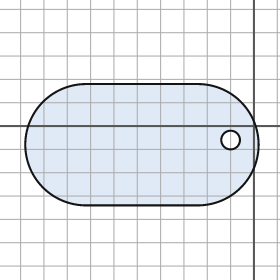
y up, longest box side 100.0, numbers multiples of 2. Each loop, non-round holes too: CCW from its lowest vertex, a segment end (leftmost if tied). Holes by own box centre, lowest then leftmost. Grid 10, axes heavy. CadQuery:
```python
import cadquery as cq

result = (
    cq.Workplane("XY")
    .moveTo(-72.0, -34.0)
    .lineTo(-24.0, -34.0)
    .threePointArc((2.0, -8.0), (-24.0, 18.0))
    .lineTo(-72.0, 18.0)
    .threePointArc((-98.0, -8.0), (-72.0, -34.0))
    .close()
    .moveTo(-10.0, -6.0)
    .circle(4.0)
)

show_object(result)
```